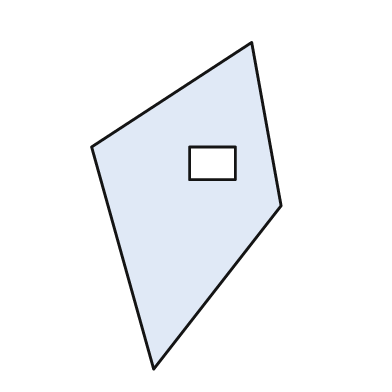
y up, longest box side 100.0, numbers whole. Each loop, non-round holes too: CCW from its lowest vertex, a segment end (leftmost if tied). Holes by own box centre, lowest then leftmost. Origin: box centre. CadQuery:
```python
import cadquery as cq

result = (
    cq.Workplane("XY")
    .moveTo(-10.0, -50.0)
    .lineTo(29.0, 0.0)
    .lineTo(20.0, 50.0)
    .lineTo(-29.0, 18.0)
    .close()
    .moveTo(1.0, 8.0)
    .lineTo(15.0, 8.0)
    .lineTo(15.0, 18.0)
    .lineTo(1.0, 18.0)
    .close()
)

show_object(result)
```